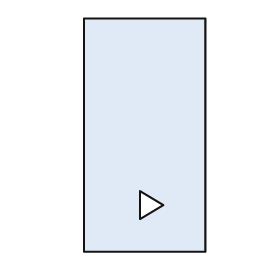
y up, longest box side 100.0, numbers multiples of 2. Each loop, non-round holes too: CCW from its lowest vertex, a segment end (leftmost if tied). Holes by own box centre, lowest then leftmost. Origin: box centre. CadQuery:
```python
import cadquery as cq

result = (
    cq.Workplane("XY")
    .moveTo(-26.0, -50.0)
    .lineTo(26.0, -50.0)
    .lineTo(26.0, 50.0)
    .lineTo(-26.0, 50.0)
    .close()
    .moveTo(-2.0, -36.0)
    .lineTo(8.0, -30.0)
    .lineTo(-2.0, -24.0)
    .close()
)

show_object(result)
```